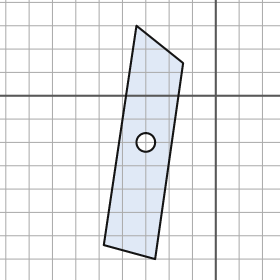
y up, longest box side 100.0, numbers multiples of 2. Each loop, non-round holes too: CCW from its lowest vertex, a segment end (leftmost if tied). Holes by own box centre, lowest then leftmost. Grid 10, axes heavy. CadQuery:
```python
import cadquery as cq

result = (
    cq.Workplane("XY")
    .moveTo(-26.0, -70.0)
    .lineTo(-14.0, 14.0)
    .lineTo(-34.0, 30.0)
    .lineTo(-48.0, -64.0)
    .close()
    .moveTo(-30.0, -20.0)
    .circle(4.0)
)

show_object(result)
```